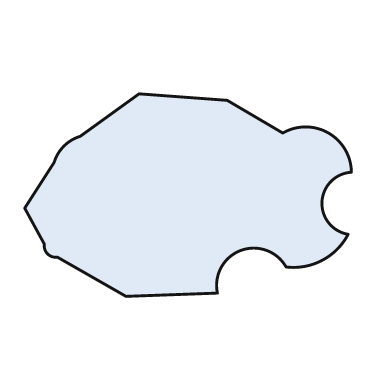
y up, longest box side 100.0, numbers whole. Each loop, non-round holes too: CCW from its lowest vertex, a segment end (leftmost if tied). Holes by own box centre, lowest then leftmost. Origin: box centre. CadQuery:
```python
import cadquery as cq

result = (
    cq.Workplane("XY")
    .moveTo(-19.0, -31.0)
    .lineTo(9.0, -30.0)
    .threePointArc((16.0, -17.0), (30.0, -22.0))
    .threePointArc((41.0, -20.0), (49.0, -12.0))
    .threePointArc((41.0, -2.0), (50.0, 7.0))
    .threePointArc((43.0, 19.0), (29.0, 19.0))
    .lineTo(12.0, 29.0)
    .lineTo(-15.0, 31.0)
    .lineTo(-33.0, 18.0)
    .threePointArc((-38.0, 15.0), (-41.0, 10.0))
    .lineTo(-50.0, -4.0)
    .lineTo(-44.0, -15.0)
    .threePointArc((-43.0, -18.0), (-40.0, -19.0))
    .close()
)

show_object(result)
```